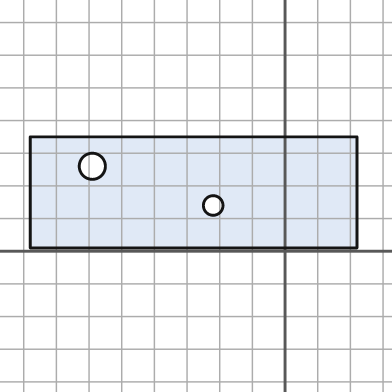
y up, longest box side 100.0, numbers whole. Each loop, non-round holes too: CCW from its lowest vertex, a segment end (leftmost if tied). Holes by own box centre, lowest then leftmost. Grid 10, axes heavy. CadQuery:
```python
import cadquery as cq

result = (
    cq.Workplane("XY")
    .moveTo(-78.0, 1.0)
    .lineTo(22.0, 1.0)
    .lineTo(22.0, 35.0)
    .lineTo(-78.0, 35.0)
    .close()
    .moveTo(-22.0, 14.0)
    .circle(3.0)
    .moveTo(-59.0, 26.0)
    .circle(4.0)
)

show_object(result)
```